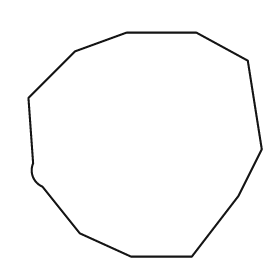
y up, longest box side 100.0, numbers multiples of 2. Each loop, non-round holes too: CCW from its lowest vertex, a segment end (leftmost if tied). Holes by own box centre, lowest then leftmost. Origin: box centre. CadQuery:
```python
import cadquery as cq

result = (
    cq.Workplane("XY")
    .moveTo(-6.0, -48.0)
    .lineTo(20.0, -48.0)
    .lineTo(40.0, -22.0)
    .lineTo(50.0, -2.0)
    .lineTo(44.0, 36.0)
    .lineTo(22.0, 48.0)
    .lineTo(-8.0, 48.0)
    .lineTo(-30.0, 40.0)
    .lineTo(-50.0, 20.0)
    .lineTo(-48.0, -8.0)
    .threePointArc((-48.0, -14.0), (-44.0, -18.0))
    .lineTo(-28.0, -38.0)
    .close()
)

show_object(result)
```